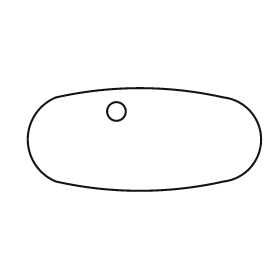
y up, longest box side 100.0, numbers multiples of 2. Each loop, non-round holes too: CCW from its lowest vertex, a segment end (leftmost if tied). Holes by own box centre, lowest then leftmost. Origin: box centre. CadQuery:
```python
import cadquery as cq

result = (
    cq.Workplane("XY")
    .moveTo(-38.0, -18.0)
    .threePointArc((-2.0, -22.0), (34.0, -18.0))
    .threePointArc((50.0, 0.0), (34.0, 18.0))
    .threePointArc((-2.0, 22.0), (-38.0, 18.0))
    .threePointArc((-50.0, 0.0), (-38.0, -18.0))
    .close()
    .moveTo(-12.0, 12.0)
    .circle(4.0)
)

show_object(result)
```